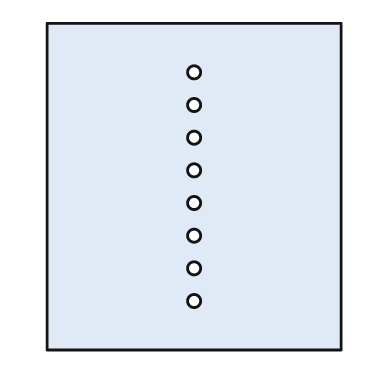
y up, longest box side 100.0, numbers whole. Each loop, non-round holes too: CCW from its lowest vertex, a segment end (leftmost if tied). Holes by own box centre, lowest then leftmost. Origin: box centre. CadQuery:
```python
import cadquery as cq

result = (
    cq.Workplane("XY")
    .moveTo(-45.0, -50.0)
    .lineTo(45.0, -50.0)
    .lineTo(45.0, 50.0)
    .lineTo(-45.0, 50.0)
    .close()
    .moveTo(0.0, -35.0)
    .circle(2.0)
    .moveTo(0.0, -25.0)
    .circle(2.0)
    .moveTo(0.0, -15.0)
    .circle(2.0)
    .moveTo(0.0, -5.0)
    .circle(2.0)
    .moveTo(0.0, 5.0)
    .circle(2.0)
    .moveTo(0.0, 15.0)
    .circle(2.0)
    .moveTo(0.0, 25.0)
    .circle(2.0)
    .moveTo(0.0, 35.0)
    .circle(2.0)
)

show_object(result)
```